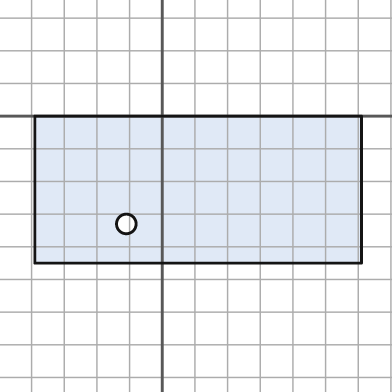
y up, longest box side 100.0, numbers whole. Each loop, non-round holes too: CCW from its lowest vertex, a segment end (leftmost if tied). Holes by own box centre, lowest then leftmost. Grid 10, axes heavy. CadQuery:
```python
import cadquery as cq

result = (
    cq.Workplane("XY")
    .moveTo(-39.0, -45.0)
    .lineTo(61.0, -45.0)
    .lineTo(61.0, 0.0)
    .lineTo(-39.0, 0.0)
    .close()
    .moveTo(-11.0, -33.0)
    .circle(3.0)
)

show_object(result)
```